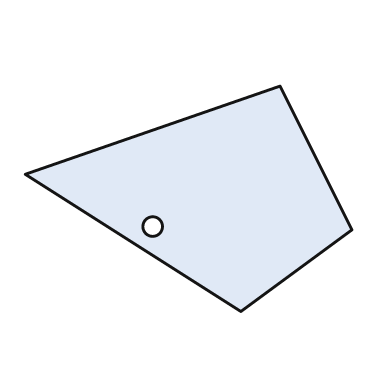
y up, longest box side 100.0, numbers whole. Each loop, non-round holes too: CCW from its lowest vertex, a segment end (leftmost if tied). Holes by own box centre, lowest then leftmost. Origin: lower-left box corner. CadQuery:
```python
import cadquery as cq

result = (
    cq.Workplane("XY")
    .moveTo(66.0, 0.0)
    .lineTo(100.0, 25.0)
    .lineTo(78.0, 69.0)
    .lineTo(0.0, 42.0)
    .close()
    .moveTo(39.0, 26.0)
    .circle(3.0)
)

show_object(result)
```